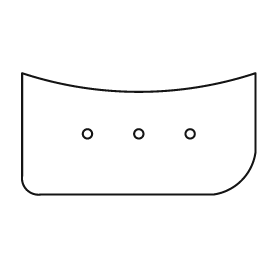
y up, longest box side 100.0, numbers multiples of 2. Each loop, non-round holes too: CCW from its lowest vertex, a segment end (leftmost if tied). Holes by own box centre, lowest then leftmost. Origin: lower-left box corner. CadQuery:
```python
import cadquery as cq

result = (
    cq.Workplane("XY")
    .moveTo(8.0, 0.0)
    .lineTo(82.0, 0.0)
    .threePointArc((94.0, 6.0), (100.0, 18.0))
    .lineTo(100.0, 52.0)
    .threePointArc((50.0, 44.0), (0.0, 52.0))
    .lineTo(0.0, 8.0)
    .threePointArc((2.0, 2.0), (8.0, 0.0))
    .close()
    .moveTo(28.0, 26.0)
    .circle(2.0)
    .moveTo(50.0, 26.0)
    .circle(2.0)
    .moveTo(72.0, 26.0)
    .circle(2.0)
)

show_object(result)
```